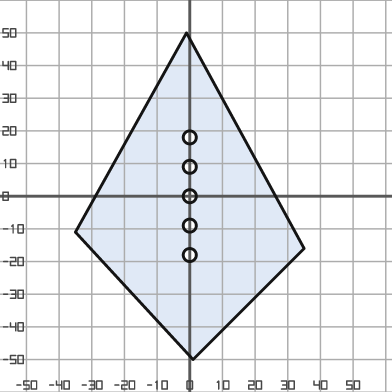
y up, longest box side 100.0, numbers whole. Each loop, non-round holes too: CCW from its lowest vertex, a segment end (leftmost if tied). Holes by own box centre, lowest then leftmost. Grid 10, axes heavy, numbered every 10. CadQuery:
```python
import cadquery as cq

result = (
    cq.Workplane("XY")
    .moveTo(1.0, -50.0)
    .lineTo(35.0, -16.0)
    .lineTo(-1.0, 50.0)
    .lineTo(-35.0, -11.0)
    .close()
    .moveTo(0.0, -18.0)
    .circle(2.0)
    .moveTo(0.0, -9.0)
    .circle(2.0)
    .moveTo(0.0, 0.0)
    .circle(2.0)
    .moveTo(0.0, 9.0)
    .circle(2.0)
    .moveTo(0.0, 18.0)
    .circle(2.0)
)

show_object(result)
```